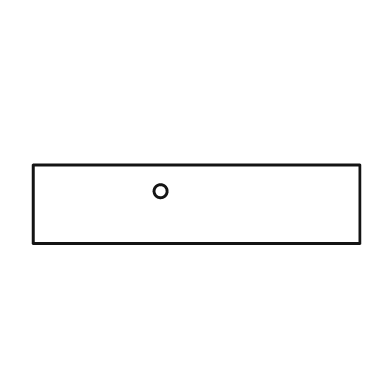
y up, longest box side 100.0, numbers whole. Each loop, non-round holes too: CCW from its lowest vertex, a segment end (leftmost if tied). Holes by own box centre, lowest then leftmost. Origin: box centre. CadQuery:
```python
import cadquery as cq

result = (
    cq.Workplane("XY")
    .moveTo(-50.0, -12.0)
    .lineTo(50.0, -12.0)
    .lineTo(50.0, 12.0)
    .lineTo(-50.0, 12.0)
    .close()
    .moveTo(-11.0, 4.0)
    .circle(2.0)
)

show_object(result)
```